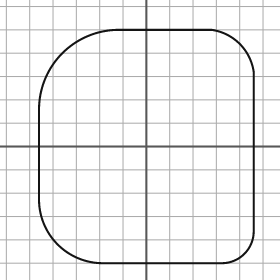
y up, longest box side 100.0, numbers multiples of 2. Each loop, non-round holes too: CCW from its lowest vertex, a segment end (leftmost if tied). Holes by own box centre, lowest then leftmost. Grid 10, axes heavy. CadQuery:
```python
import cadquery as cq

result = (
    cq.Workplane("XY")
    .moveTo(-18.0, -50.0)
    .lineTo(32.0, -50.0)
    .threePointArc((42.0, -46.0), (46.0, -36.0))
    .lineTo(46.0, 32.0)
    .threePointArc((40.0, 44.0), (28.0, 50.0))
    .lineTo(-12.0, 50.0)
    .threePointArc((-36.0, 40.0), (-46.0, 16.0))
    .lineTo(-46.0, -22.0)
    .threePointArc((-38.0, -42.0), (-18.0, -50.0))
    .close()
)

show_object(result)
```